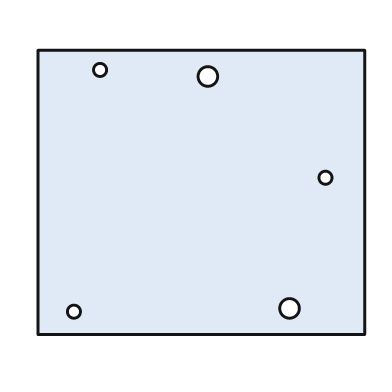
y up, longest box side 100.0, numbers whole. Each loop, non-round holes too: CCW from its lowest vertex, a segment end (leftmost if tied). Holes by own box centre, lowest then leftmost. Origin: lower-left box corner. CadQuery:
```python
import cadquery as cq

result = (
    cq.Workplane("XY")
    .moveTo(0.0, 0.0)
    .lineTo(100.0, 0.0)
    .lineTo(100.0, 87.0)
    .lineTo(0.0, 87.0)
    .close()
    .moveTo(11.0, 7.0)
    .circle(2.0)
    .moveTo(77.0, 8.0)
    .circle(3.0)
    .moveTo(88.0, 48.0)
    .circle(2.0)
    .moveTo(52.0, 79.0)
    .circle(3.0)
    .moveTo(19.0, 81.0)
    .circle(2.0)
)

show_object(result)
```